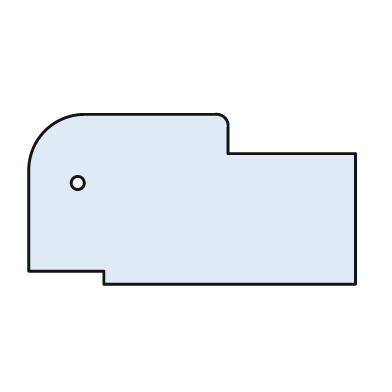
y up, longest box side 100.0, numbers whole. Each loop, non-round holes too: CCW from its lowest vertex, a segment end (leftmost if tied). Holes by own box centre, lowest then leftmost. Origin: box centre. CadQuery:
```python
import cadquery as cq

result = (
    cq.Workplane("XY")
    .moveTo(-27.0, -26.0)
    .lineTo(50.0, -26.0)
    .lineTo(50.0, 14.0)
    .lineTo(11.0, 14.0)
    .lineTo(11.0, 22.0)
    .threePointArc((10.0, 25.0), (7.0, 26.0))
    .lineTo(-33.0, 26.0)
    .threePointArc((-45.0, 21.0), (-50.0, 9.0))
    .lineTo(-50.0, -22.0)
    .lineTo(-27.0, -22.0)
    .close()
    .moveTo(-35.0, 5.0)
    .circle(2.0)
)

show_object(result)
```